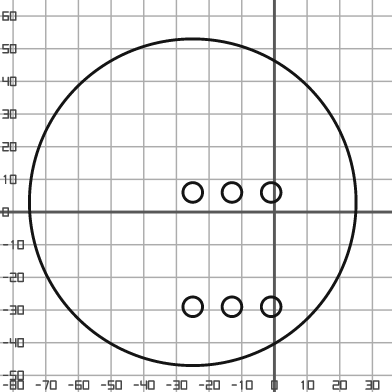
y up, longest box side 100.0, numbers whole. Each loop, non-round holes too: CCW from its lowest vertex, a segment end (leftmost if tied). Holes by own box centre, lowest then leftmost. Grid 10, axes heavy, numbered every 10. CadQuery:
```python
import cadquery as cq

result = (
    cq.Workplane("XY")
    .moveTo(-25.0, 3.0)
    .circle(50.0)
    .moveTo(-25.0, -29.0)
    .circle(3.0)
    .moveTo(-13.0, -29.0)
    .circle(3.0)
    .moveTo(-1.0, -29.0)
    .circle(3.0)
    .moveTo(-25.0, 6.0)
    .circle(3.0)
    .moveTo(-13.0, 6.0)
    .circle(3.0)
    .moveTo(-1.0, 6.0)
    .circle(3.0)
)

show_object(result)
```